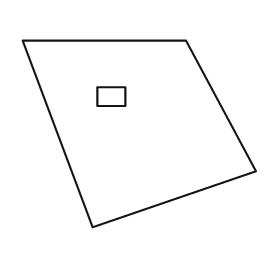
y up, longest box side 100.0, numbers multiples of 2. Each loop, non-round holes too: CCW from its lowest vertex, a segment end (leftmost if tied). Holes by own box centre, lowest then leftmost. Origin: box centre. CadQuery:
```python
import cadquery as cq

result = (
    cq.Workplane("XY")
    .moveTo(-20.0, -40.0)
    .lineTo(50.0, -16.0)
    .lineTo(20.0, 40.0)
    .lineTo(-50.0, 40.0)
    .close()
    .moveTo(-18.0, 12.0)
    .lineTo(-6.0, 12.0)
    .lineTo(-6.0, 20.0)
    .lineTo(-18.0, 20.0)
    .close()
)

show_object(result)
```